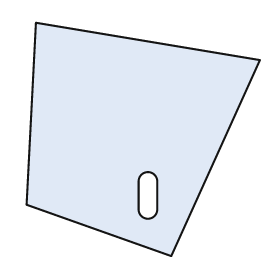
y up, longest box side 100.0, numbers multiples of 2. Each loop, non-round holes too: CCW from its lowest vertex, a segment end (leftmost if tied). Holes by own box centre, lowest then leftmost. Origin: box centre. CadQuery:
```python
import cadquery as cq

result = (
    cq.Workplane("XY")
    .moveTo(12.0, -50.0)
    .lineTo(50.0, 34.0)
    .lineTo(-46.0, 50.0)
    .lineTo(-50.0, -28.0)
    .close()
    .moveTo(-2.0, -30.0)
    .threePointArc((2.0, -34.0), (6.0, -30.0))
    .lineTo(6.0, -18.0)
    .threePointArc((2.0, -14.0), (-2.0, -18.0))
    .close()
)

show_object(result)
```